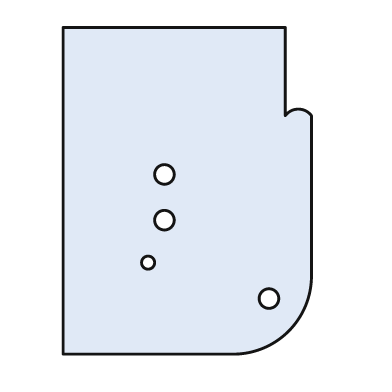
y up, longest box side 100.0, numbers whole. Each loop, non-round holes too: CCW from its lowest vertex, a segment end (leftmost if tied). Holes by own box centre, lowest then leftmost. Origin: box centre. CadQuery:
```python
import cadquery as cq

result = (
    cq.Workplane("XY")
    .moveTo(-38.0, -50.0)
    .lineTo(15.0, -50.0)
    .threePointArc((31.0, -43.0), (38.0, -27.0))
    .lineTo(38.0, 23.0)
    .threePointArc((34.0, 25.0), (30.0, 23.0))
    .lineTo(30.0, 50.0)
    .lineTo(-38.0, 50.0)
    .close()
    .moveTo(25.0, -33.0)
    .circle(3.0)
    .moveTo(-12.0, -22.0)
    .circle(2.0)
    .moveTo(-7.0, -9.0)
    .circle(3.0)
    .moveTo(-7.0, 5.0)
    .circle(3.0)
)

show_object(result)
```